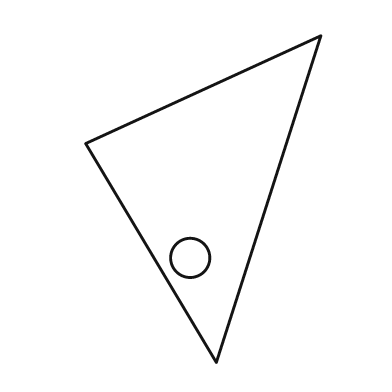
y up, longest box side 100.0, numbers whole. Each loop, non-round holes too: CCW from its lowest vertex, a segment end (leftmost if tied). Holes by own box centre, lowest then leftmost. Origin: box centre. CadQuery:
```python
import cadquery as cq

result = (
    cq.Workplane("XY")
    .moveTo(4.0, -50.0)
    .lineTo(36.0, 50.0)
    .lineTo(-36.0, 17.0)
    .close()
    .moveTo(-4.0, -18.0)
    .circle(6.0)
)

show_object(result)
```